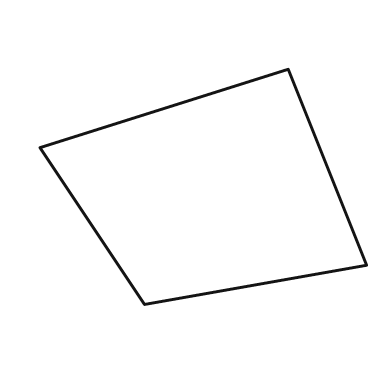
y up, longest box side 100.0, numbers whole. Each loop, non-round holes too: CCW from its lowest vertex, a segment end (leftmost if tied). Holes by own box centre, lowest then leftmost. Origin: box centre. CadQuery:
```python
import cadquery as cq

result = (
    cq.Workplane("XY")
    .moveTo(-18.0, -36.0)
    .lineTo(50.0, -24.0)
    .lineTo(26.0, 36.0)
    .lineTo(-50.0, 12.0)
    .close()
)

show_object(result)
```